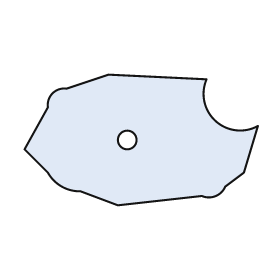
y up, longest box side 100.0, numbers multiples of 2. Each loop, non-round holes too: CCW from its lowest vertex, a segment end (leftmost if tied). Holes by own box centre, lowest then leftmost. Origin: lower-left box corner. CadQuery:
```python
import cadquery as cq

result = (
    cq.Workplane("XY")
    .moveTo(40.0, 0.0)
    .lineTo(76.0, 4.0)
    .threePointArc((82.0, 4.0), (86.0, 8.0))
    .lineTo(94.0, 14.0)
    .lineTo(100.0, 34.0)
    .threePointArc((82.0, 36.0), (78.0, 54.0))
    .lineTo(36.0, 56.0)
    .lineTo(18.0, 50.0)
    .threePointArc((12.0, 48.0), (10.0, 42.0))
    .lineTo(0.0, 24.0)
    .lineTo(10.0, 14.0)
    .threePointArc((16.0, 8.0), (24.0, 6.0))
    .close()
    .moveTo(44.0, 28.0)
    .circle(4.0)
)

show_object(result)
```